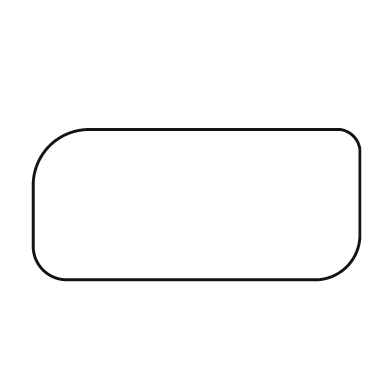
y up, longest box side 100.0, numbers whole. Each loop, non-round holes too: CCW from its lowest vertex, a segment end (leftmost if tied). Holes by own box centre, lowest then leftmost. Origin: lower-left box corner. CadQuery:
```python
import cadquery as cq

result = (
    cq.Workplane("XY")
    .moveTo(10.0, 0.0)
    .lineTo(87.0, 0.0)
    .threePointArc((96.0, 4.0), (100.0, 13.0))
    .lineTo(100.0, 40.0)
    .threePointArc((98.0, 44.0), (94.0, 46.0))
    .lineTo(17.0, 46.0)
    .threePointArc((5.0, 41.0), (0.0, 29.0))
    .lineTo(0.0, 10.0)
    .threePointArc((3.0, 3.0), (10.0, 0.0))
    .close()
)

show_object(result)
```